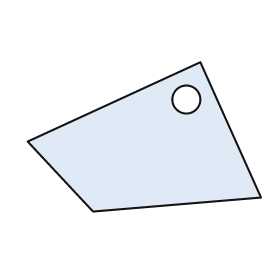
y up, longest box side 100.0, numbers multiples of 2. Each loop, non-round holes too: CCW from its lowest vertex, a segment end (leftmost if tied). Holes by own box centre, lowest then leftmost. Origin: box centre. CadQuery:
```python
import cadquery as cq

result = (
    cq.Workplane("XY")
    .moveTo(-22.0, -32.0)
    .lineTo(50.0, -26.0)
    .lineTo(24.0, 32.0)
    .lineTo(-50.0, -2.0)
    .close()
    .moveTo(18.0, 16.0)
    .circle(6.0)
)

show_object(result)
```